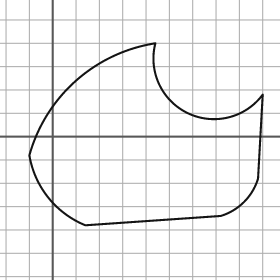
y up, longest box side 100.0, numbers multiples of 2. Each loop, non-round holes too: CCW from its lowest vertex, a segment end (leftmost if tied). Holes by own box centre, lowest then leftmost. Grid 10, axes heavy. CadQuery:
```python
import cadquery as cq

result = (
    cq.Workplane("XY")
    .moveTo(14.0, -38.0)
    .lineTo(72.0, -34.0)
    .threePointArc((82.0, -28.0), (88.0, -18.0))
    .lineTo(90.0, 18.0)
    .threePointArc((58.0, 10.0), (44.0, 40.0))
    .threePointArc((10.0, 24.0), (-10.0, -8.0))
    .threePointArc((-2.0, -26.0), (14.0, -38.0))
    .close()
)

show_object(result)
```